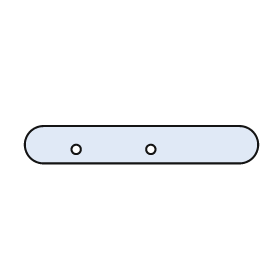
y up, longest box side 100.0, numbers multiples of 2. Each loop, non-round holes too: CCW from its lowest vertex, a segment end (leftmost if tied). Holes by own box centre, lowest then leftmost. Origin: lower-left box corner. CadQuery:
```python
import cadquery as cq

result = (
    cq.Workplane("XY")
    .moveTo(8.0, 0.0)
    .lineTo(92.0, 0.0)
    .threePointArc((100.0, 8.0), (92.0, 16.0))
    .lineTo(8.0, 16.0)
    .threePointArc((0.0, 8.0), (8.0, 0.0))
    .close()
    .moveTo(22.0, 6.0)
    .circle(2.0)
    .moveTo(54.0, 6.0)
    .circle(2.0)
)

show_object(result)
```